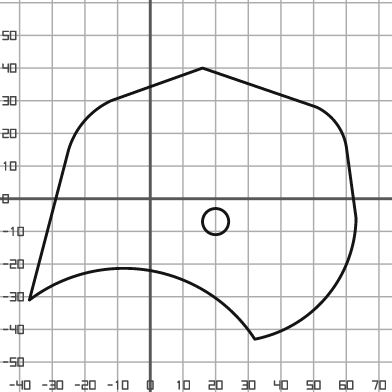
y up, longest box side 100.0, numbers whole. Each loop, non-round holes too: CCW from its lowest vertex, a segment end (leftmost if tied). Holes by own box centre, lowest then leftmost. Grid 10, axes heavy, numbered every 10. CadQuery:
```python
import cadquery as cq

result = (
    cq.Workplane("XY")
    .moveTo(32.0, -43.0)
    .threePointArc((54.0, -30.0), (63.0, -6.0))
    .lineTo(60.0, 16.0)
    .threePointArc((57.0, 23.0), (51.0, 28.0))
    .lineTo(16.0, 40.0)
    .lineTo(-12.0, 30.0)
    .threePointArc((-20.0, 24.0), (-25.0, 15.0))
    .lineTo(-37.0, -31.0)
    .threePointArc((0.0, -22.0), (32.0, -43.0))
    .close()
    .moveTo(20.0, -7.0)
    .circle(4.0)
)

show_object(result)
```